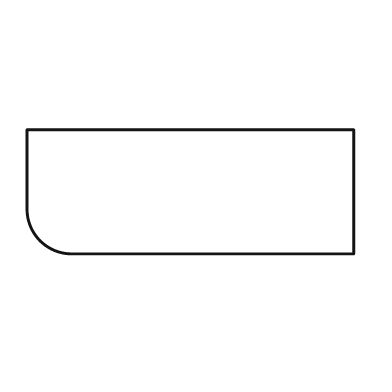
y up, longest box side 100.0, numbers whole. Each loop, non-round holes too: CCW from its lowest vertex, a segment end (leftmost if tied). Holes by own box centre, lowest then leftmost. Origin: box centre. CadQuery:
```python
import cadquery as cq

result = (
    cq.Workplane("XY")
    .moveTo(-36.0, -19.0)
    .lineTo(50.0, -19.0)
    .lineTo(50.0, 19.0)
    .lineTo(-50.0, 19.0)
    .lineTo(-50.0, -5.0)
    .threePointArc((-46.0, -15.0), (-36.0, -19.0))
    .close()
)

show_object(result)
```